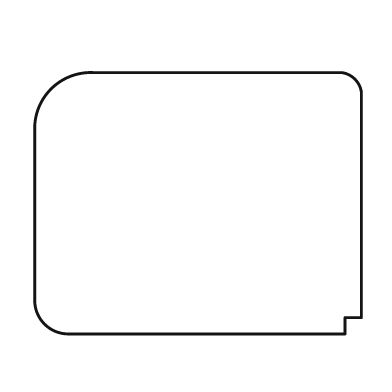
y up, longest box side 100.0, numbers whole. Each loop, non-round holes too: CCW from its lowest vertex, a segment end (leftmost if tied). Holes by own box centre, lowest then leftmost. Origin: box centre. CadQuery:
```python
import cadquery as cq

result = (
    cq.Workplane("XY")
    .moveTo(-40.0, -40.0)
    .lineTo(45.0, -40.0)
    .lineTo(45.0, -35.0)
    .lineTo(50.0, -35.0)
    .lineTo(50.0, 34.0)
    .threePointArc((48.0, 38.0), (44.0, 40.0))
    .lineTo(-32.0, 40.0)
    .threePointArc((-45.0, 35.0), (-50.0, 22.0))
    .lineTo(-50.0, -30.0)
    .threePointArc((-47.0, -37.0), (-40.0, -40.0))
    .close()
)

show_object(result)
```